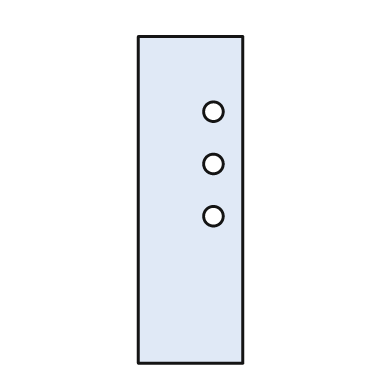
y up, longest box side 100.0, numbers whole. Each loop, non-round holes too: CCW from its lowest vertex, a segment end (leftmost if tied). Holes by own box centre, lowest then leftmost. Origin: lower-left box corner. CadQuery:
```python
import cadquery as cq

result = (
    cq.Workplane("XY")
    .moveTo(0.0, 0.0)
    .lineTo(32.0, 0.0)
    .lineTo(32.0, 100.0)
    .lineTo(0.0, 100.0)
    .close()
    .moveTo(23.0, 45.0)
    .circle(3.0)
    .moveTo(23.0, 61.0)
    .circle(3.0)
    .moveTo(23.0, 77.0)
    .circle(3.0)
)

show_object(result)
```